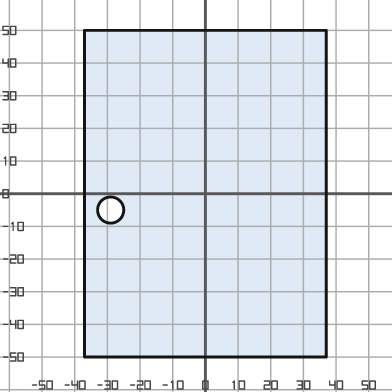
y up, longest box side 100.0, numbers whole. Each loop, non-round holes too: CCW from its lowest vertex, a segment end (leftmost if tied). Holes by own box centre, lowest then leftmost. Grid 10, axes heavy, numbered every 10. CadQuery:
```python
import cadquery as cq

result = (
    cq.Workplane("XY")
    .moveTo(-37.0, -50.0)
    .lineTo(37.0, -50.0)
    .lineTo(37.0, 50.0)
    .lineTo(-37.0, 50.0)
    .close()
    .moveTo(-29.0, -5.0)
    .circle(4.0)
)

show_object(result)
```